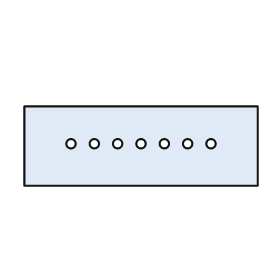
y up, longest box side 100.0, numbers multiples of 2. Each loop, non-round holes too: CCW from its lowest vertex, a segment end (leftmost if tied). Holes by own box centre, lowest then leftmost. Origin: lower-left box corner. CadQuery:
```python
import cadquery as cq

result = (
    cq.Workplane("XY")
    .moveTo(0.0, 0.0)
    .lineTo(100.0, 0.0)
    .lineTo(100.0, 34.0)
    .lineTo(0.0, 34.0)
    .close()
    .moveTo(20.0, 18.0)
    .circle(2.0)
    .moveTo(30.0, 18.0)
    .circle(2.0)
    .moveTo(40.0, 18.0)
    .circle(2.0)
    .moveTo(50.0, 18.0)
    .circle(2.0)
    .moveTo(60.0, 18.0)
    .circle(2.0)
    .moveTo(70.0, 18.0)
    .circle(2.0)
    .moveTo(80.0, 18.0)
    .circle(2.0)
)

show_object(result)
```